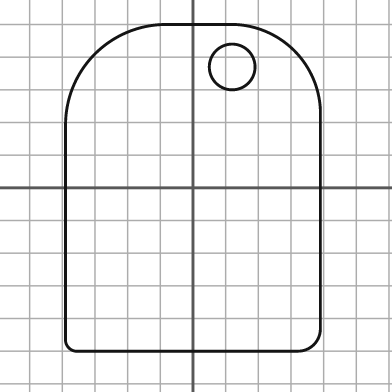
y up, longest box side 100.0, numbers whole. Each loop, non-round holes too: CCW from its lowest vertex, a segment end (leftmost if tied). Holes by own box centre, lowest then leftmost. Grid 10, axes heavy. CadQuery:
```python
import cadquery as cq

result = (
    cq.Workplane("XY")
    .moveTo(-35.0, -50.0)
    .lineTo(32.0, -50.0)
    .threePointArc((37.0, -48.0), (39.0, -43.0))
    .lineTo(39.0, 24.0)
    .threePointArc((31.0, 42.0), (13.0, 50.0))
    .lineTo(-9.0, 50.0)
    .threePointArc((-30.0, 41.0), (-39.0, 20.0))
    .lineTo(-39.0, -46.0)
    .threePointArc((-38.0, -49.0), (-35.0, -50.0))
    .close()
    .moveTo(12.0, 37.0)
    .circle(7.0)
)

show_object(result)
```